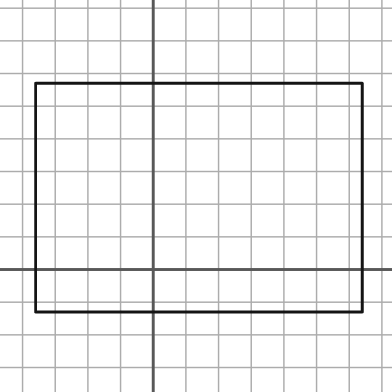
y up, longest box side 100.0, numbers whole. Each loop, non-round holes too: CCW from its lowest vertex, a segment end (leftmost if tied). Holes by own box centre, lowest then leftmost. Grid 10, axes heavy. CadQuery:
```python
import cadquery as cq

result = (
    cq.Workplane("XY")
    .moveTo(-36.0, -13.0)
    .lineTo(64.0, -13.0)
    .lineTo(64.0, 57.0)
    .lineTo(-36.0, 57.0)
    .close()
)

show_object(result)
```